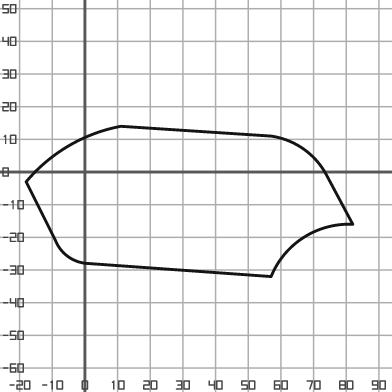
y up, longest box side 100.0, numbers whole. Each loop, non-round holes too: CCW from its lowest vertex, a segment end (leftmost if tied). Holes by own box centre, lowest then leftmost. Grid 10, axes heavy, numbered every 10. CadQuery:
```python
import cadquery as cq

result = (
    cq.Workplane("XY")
    .moveTo(57.0, -32.0)
    .threePointArc((67.0, -20.0), (82.0, -16.0))
    .lineTo(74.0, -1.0)
    .threePointArc((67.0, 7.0), (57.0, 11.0))
    .lineTo(11.0, 14.0)
    .threePointArc((-5.0, 8.0), (-18.0, -3.0))
    .lineTo(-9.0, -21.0)
    .threePointArc((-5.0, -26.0), (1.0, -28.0))
    .close()
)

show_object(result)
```